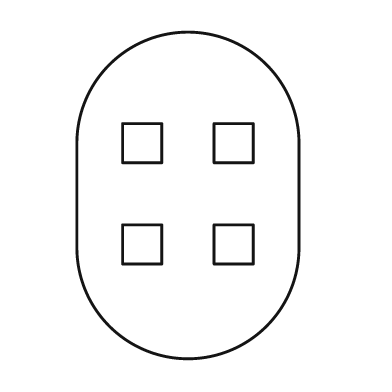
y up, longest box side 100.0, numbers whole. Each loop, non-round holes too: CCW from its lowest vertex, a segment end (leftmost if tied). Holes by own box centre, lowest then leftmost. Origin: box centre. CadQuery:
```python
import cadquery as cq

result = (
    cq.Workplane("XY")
    .moveTo(-34.0, -16.0)
    .threePointArc((0.0, -50.0), (34.0, -16.0))
    .lineTo(34.0, 16.0)
    .threePointArc((0.0, 50.0), (-34.0, 16.0))
    .close()
    .moveTo(-20.0, -21.0)
    .lineTo(-8.0, -21.0)
    .lineTo(-8.0, -9.0)
    .lineTo(-20.0, -9.0)
    .close()
    .moveTo(8.0, -21.0)
    .lineTo(20.0, -21.0)
    .lineTo(20.0, -9.0)
    .lineTo(8.0, -9.0)
    .close()
    .moveTo(-20.0, 10.0)
    .lineTo(-8.0, 10.0)
    .lineTo(-8.0, 22.0)
    .lineTo(-20.0, 22.0)
    .close()
    .moveTo(8.0, 10.0)
    .lineTo(20.0, 10.0)
    .lineTo(20.0, 22.0)
    .lineTo(8.0, 22.0)
    .close()
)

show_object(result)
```